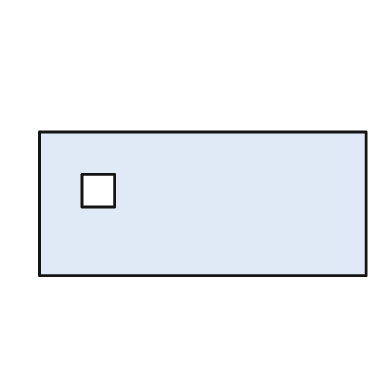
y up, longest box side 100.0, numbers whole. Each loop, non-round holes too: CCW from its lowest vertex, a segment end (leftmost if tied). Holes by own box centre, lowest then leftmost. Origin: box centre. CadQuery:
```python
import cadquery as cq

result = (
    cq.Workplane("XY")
    .moveTo(-50.0, -22.0)
    .lineTo(50.0, -22.0)
    .lineTo(50.0, 22.0)
    .lineTo(-50.0, 22.0)
    .close()
    .moveTo(-37.0, -1.0)
    .lineTo(-27.0, -1.0)
    .lineTo(-27.0, 9.0)
    .lineTo(-37.0, 9.0)
    .close()
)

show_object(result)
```